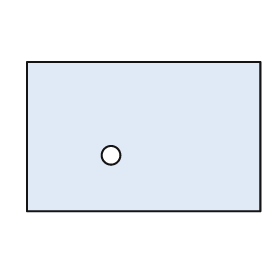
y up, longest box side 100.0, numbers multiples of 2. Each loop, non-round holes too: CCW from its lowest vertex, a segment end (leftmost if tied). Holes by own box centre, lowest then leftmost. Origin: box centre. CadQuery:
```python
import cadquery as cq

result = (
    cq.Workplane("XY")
    .moveTo(-50.0, -32.0)
    .lineTo(50.0, -32.0)
    .lineTo(50.0, 32.0)
    .lineTo(-50.0, 32.0)
    .close()
    .moveTo(-14.0, -8.0)
    .circle(4.0)
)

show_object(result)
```